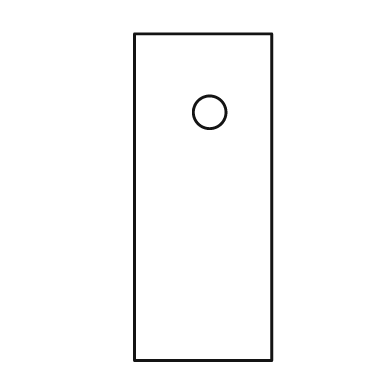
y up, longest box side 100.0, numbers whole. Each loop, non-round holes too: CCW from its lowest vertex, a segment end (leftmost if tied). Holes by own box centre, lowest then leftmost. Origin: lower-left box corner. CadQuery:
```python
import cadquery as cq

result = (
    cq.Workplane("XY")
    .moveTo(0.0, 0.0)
    .lineTo(42.0, 0.0)
    .lineTo(42.0, 100.0)
    .lineTo(0.0, 100.0)
    .close()
    .moveTo(23.0, 76.0)
    .circle(5.0)
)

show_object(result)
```